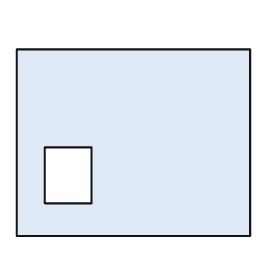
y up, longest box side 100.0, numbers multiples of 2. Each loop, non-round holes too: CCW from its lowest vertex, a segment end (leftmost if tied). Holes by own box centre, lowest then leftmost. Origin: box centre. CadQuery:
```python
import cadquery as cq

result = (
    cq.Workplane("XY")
    .moveTo(-50.0, -40.0)
    .lineTo(50.0, -40.0)
    .lineTo(50.0, 40.0)
    .lineTo(-50.0, 40.0)
    .close()
    .moveTo(-38.0, -26.0)
    .lineTo(-18.0, -26.0)
    .lineTo(-18.0, -2.0)
    .lineTo(-38.0, -2.0)
    .close()
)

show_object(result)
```